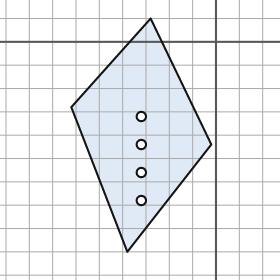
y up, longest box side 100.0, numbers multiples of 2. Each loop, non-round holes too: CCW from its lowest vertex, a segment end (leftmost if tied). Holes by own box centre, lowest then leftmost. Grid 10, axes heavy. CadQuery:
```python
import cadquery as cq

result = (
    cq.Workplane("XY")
    .moveTo(-38.0, -90.0)
    .lineTo(-2.0, -44.0)
    .lineTo(-28.0, 10.0)
    .lineTo(-62.0, -28.0)
    .close()
    .moveTo(-32.0, -68.0)
    .circle(2.0)
    .moveTo(-32.0, -56.0)
    .circle(2.0)
    .moveTo(-32.0, -44.0)
    .circle(2.0)
    .moveTo(-32.0, -32.0)
    .circle(2.0)
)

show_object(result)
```